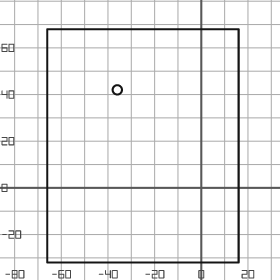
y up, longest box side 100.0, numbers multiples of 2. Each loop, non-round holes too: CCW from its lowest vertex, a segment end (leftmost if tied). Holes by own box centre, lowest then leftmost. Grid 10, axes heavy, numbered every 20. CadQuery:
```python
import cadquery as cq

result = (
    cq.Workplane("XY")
    .moveTo(-66.0, -32.0)
    .lineTo(16.0, -32.0)
    .lineTo(16.0, 68.0)
    .lineTo(-66.0, 68.0)
    .close()
    .moveTo(-36.0, 42.0)
    .circle(2.0)
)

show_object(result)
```